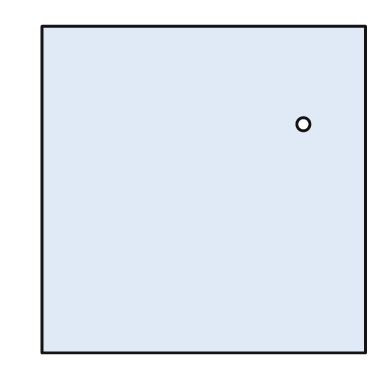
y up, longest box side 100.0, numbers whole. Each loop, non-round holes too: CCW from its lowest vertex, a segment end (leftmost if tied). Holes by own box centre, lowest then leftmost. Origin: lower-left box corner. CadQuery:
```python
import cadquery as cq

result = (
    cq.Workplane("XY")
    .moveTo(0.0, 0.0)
    .lineTo(99.0, 0.0)
    .lineTo(99.0, 100.0)
    .lineTo(0.0, 100.0)
    .close()
    .moveTo(80.0, 70.0)
    .circle(2.0)
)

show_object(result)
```